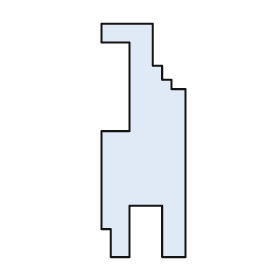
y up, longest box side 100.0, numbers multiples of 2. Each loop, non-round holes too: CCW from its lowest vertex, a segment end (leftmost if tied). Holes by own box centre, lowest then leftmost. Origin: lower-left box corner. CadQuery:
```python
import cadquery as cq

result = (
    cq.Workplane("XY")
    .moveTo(4.0, 0.0)
    .lineTo(12.0, 0.0)
    .lineTo(12.0, 22.0)
    .lineTo(26.0, 22.0)
    .lineTo(26.0, 0.0)
    .lineTo(36.0, 0.0)
    .lineTo(36.0, 72.0)
    .lineTo(30.0, 72.0)
    .lineTo(30.0, 76.0)
    .lineTo(26.0, 76.0)
    .lineTo(26.0, 82.0)
    .lineTo(22.0, 82.0)
    .lineTo(22.0, 100.0)
    .lineTo(0.0, 100.0)
    .lineTo(0.0, 92.0)
    .lineTo(12.0, 92.0)
    .lineTo(12.0, 54.0)
    .lineTo(0.0, 54.0)
    .lineTo(0.0, 12.0)
    .lineTo(4.0, 12.0)
    .close()
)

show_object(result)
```